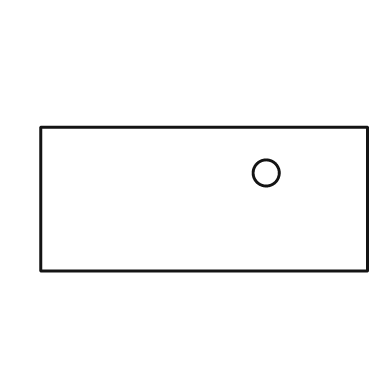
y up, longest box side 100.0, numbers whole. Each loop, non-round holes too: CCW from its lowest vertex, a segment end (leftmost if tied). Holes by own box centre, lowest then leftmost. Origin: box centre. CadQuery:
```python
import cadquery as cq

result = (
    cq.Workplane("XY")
    .moveTo(-50.0, -22.0)
    .lineTo(50.0, -22.0)
    .lineTo(50.0, 22.0)
    .lineTo(-50.0, 22.0)
    .close()
    .moveTo(19.0, 8.0)
    .circle(4.0)
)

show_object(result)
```